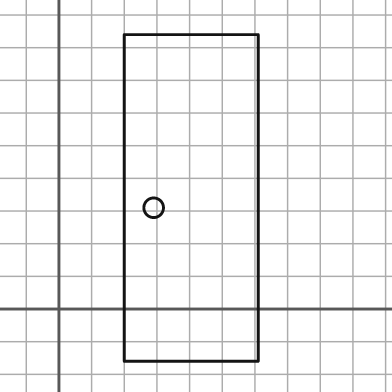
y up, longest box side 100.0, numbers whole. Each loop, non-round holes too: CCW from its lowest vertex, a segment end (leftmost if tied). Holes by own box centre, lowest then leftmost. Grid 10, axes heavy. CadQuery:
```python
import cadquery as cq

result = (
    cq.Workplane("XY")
    .moveTo(20.0, -16.0)
    .lineTo(61.0, -16.0)
    .lineTo(61.0, 84.0)
    .lineTo(20.0, 84.0)
    .close()
    .moveTo(29.0, 31.0)
    .circle(3.0)
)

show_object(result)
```